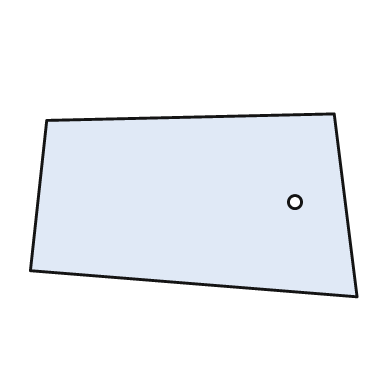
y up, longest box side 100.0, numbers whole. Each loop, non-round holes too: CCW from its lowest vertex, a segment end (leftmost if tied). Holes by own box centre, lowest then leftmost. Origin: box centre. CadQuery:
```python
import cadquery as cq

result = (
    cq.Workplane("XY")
    .moveTo(50.0, -28.0)
    .lineTo(43.0, 28.0)
    .lineTo(-45.0, 26.0)
    .lineTo(-50.0, -20.0)
    .close()
    .moveTo(31.0, 1.0)
    .circle(2.0)
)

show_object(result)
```